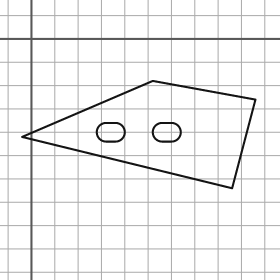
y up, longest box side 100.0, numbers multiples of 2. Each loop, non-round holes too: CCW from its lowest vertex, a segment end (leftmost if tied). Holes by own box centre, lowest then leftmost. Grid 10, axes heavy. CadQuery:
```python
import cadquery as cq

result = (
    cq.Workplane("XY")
    .moveTo(86.0, -64.0)
    .lineTo(96.0, -26.0)
    .lineTo(52.0, -18.0)
    .lineTo(-4.0, -42.0)
    .close()
    .moveTo(32.0, -44.0)
    .lineTo(36.0, -44.0)
    .threePointArc((40.0, -40.0), (36.0, -36.0))
    .lineTo(32.0, -36.0)
    .threePointArc((28.0, -40.0), (32.0, -44.0))
    .close()
    .moveTo(56.0, -44.0)
    .lineTo(60.0, -44.0)
    .threePointArc((64.0, -40.0), (60.0, -36.0))
    .lineTo(56.0, -36.0)
    .threePointArc((52.0, -40.0), (56.0, -44.0))
    .close()
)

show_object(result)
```